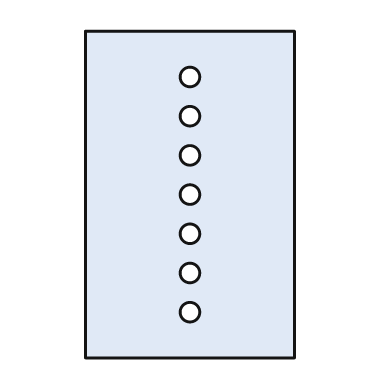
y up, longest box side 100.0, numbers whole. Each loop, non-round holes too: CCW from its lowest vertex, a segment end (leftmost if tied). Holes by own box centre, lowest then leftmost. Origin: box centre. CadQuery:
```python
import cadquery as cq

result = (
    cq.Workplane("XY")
    .moveTo(-32.0, -50.0)
    .lineTo(32.0, -50.0)
    .lineTo(32.0, 50.0)
    .lineTo(-32.0, 50.0)
    .close()
    .moveTo(0.0, -36.0)
    .circle(3.0)
    .moveTo(0.0, -24.0)
    .circle(3.0)
    .moveTo(0.0, -12.0)
    .circle(3.0)
    .moveTo(0.0, 0.0)
    .circle(3.0)
    .moveTo(0.0, 12.0)
    .circle(3.0)
    .moveTo(0.0, 24.0)
    .circle(3.0)
    .moveTo(0.0, 36.0)
    .circle(3.0)
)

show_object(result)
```